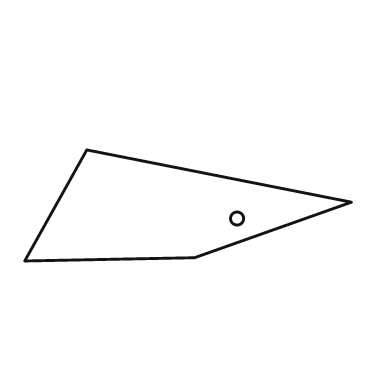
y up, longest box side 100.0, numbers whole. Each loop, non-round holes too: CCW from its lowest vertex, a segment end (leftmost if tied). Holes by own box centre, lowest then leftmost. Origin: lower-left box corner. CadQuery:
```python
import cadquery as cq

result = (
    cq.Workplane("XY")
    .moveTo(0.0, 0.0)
    .lineTo(52.0, 1.0)
    .lineTo(100.0, 18.0)
    .lineTo(19.0, 34.0)
    .close()
    .moveTo(65.0, 13.0)
    .circle(2.0)
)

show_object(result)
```